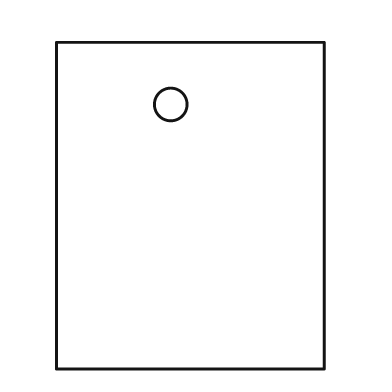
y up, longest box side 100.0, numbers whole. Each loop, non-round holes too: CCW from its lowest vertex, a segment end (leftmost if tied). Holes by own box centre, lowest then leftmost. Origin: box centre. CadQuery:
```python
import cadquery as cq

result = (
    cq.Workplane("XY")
    .moveTo(-41.0, -50.0)
    .lineTo(41.0, -50.0)
    .lineTo(41.0, 50.0)
    .lineTo(-41.0, 50.0)
    .close()
    .moveTo(-6.0, 31.0)
    .circle(5.0)
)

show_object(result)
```